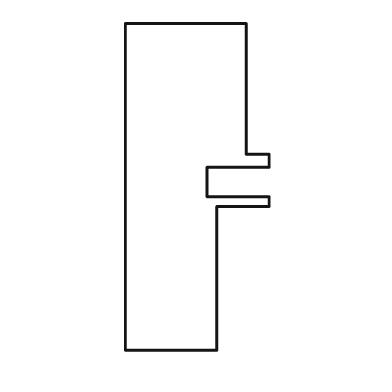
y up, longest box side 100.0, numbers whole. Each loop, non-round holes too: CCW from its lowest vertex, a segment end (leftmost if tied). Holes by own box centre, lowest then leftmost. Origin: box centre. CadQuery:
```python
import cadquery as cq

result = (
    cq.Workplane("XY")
    .moveTo(-22.0, -50.0)
    .lineTo(6.0, -50.0)
    .lineTo(6.0, -6.0)
    .lineTo(22.0, -6.0)
    .lineTo(22.0, -3.0)
    .lineTo(3.0, -3.0)
    .lineTo(3.0, 6.0)
    .lineTo(22.0, 6.0)
    .lineTo(22.0, 10.0)
    .lineTo(15.0, 10.0)
    .lineTo(15.0, 50.0)
    .lineTo(-22.0, 50.0)
    .close()
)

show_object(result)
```